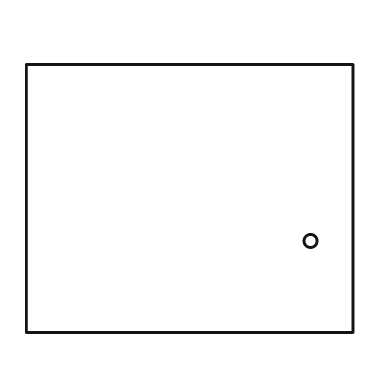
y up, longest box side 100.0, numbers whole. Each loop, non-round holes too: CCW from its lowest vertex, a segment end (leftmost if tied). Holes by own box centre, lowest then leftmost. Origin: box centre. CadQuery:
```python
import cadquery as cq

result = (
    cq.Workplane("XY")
    .moveTo(-50.0, -41.0)
    .lineTo(50.0, -41.0)
    .lineTo(50.0, 41.0)
    .lineTo(-50.0, 41.0)
    .close()
    .moveTo(37.0, -13.0)
    .circle(2.0)
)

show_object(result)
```